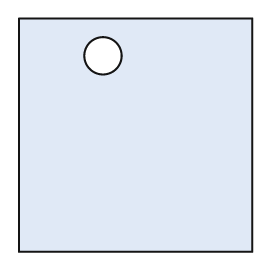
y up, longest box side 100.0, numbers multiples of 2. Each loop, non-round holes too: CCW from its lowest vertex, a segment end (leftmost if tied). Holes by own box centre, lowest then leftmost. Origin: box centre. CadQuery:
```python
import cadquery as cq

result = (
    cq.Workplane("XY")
    .moveTo(-50.0, -50.0)
    .lineTo(50.0, -50.0)
    .lineTo(50.0, 50.0)
    .lineTo(-50.0, 50.0)
    .close()
    .moveTo(-14.0, 34.0)
    .circle(8.0)
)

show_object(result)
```